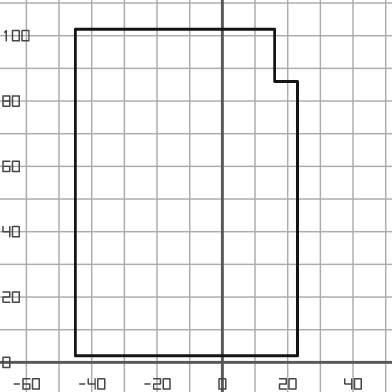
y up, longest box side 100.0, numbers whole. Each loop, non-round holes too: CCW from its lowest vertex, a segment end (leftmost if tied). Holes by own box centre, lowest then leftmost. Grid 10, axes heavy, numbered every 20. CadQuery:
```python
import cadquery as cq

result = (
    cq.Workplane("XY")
    .moveTo(-45.0, 2.0)
    .lineTo(23.0, 2.0)
    .lineTo(23.0, 86.0)
    .lineTo(16.0, 86.0)
    .lineTo(16.0, 102.0)
    .lineTo(-45.0, 102.0)
    .close()
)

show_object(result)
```